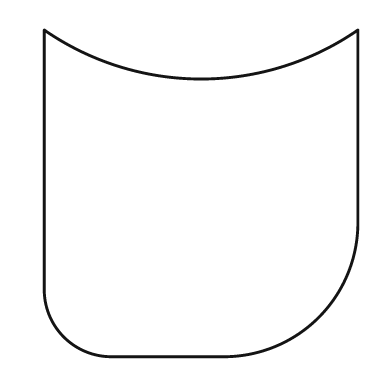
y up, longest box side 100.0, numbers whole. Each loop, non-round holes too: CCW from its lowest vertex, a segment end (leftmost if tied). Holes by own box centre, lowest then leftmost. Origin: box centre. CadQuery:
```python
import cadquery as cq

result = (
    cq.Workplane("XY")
    .moveTo(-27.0, -50.0)
    .lineTo(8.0, -50.0)
    .threePointArc((36.0, -38.0), (48.0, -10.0))
    .lineTo(48.0, 50.0)
    .threePointArc((0.0, 35.0), (-48.0, 50.0))
    .lineTo(-48.0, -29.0)
    .threePointArc((-42.0, -44.0), (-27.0, -50.0))
    .close()
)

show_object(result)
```